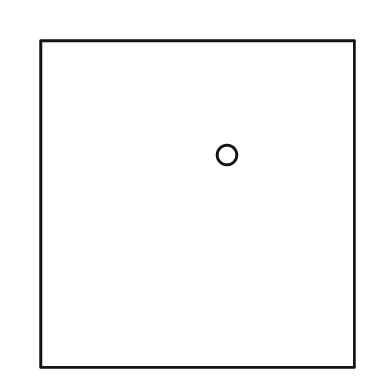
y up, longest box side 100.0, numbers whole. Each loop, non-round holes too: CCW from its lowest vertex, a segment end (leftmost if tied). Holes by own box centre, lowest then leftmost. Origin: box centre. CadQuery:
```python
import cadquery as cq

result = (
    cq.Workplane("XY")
    .moveTo(-48.0, -50.0)
    .lineTo(48.0, -50.0)
    .lineTo(48.0, 50.0)
    .lineTo(-48.0, 50.0)
    .close()
    .moveTo(9.0, 15.0)
    .circle(3.0)
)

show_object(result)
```